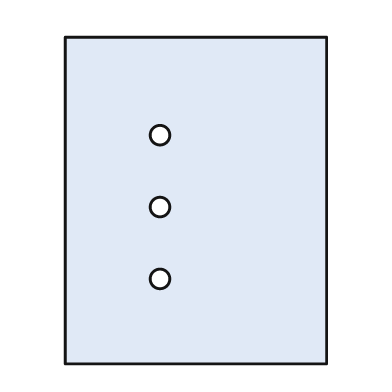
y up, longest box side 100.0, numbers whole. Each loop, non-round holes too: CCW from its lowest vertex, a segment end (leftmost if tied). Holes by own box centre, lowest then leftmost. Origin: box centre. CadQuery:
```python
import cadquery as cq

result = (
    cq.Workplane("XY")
    .moveTo(-40.0, -50.0)
    .lineTo(40.0, -50.0)
    .lineTo(40.0, 50.0)
    .lineTo(-40.0, 50.0)
    .close()
    .moveTo(-11.0, -24.0)
    .circle(3.0)
    .moveTo(-11.0, -2.0)
    .circle(3.0)
    .moveTo(-11.0, 20.0)
    .circle(3.0)
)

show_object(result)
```